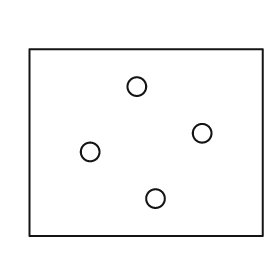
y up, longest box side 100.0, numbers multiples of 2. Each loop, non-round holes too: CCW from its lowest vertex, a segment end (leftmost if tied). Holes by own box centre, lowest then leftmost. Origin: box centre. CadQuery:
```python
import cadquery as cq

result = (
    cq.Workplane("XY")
    .moveTo(-50.0, -40.0)
    .lineTo(50.0, -40.0)
    .lineTo(50.0, 40.0)
    .lineTo(-50.0, 40.0)
    .close()
    .moveTo(4.0, -24.0)
    .circle(4.0)
    .moveTo(-24.0, -4.0)
    .circle(4.0)
    .moveTo(24.0, 4.0)
    .circle(4.0)
    .moveTo(-4.0, 24.0)
    .circle(4.0)
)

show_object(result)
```